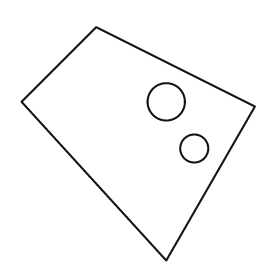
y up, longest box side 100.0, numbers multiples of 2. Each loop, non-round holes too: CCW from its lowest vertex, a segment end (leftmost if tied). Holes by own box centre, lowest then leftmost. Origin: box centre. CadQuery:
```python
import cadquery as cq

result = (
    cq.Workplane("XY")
    .moveTo(12.0, -50.0)
    .lineTo(50.0, 16.0)
    .lineTo(-18.0, 50.0)
    .lineTo(-50.0, 18.0)
    .close()
    .moveTo(24.0, -2.0)
    .circle(6.0)
    .moveTo(12.0, 18.0)
    .circle(8.0)
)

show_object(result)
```